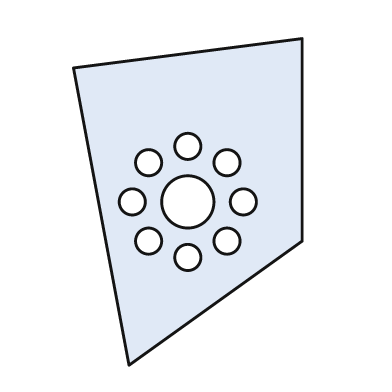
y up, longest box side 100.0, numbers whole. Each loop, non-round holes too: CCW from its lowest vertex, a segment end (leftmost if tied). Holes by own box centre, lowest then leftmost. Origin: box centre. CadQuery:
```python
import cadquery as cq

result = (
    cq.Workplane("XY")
    .moveTo(-18.0, -50.0)
    .lineTo(35.0, -12.0)
    .lineTo(35.0, 50.0)
    .lineTo(-35.0, 41.0)
    .close()
    .moveTo(0.0, -17.0)
    .circle(4.0)
    .moveTo(-12.0, -12.0)
    .circle(4.0)
    .moveTo(12.0, -12.0)
    .circle(4.0)
    .moveTo(-17.0, 0.0)
    .circle(4.0)
    .moveTo(0.0, 0.0)
    .circle(8.0)
    .moveTo(17.0, 0.0)
    .circle(4.0)
    .moveTo(-12.0, 12.0)
    .circle(4.0)
    .moveTo(12.0, 12.0)
    .circle(4.0)
    .moveTo(0.0, 17.0)
    .circle(4.0)
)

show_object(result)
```